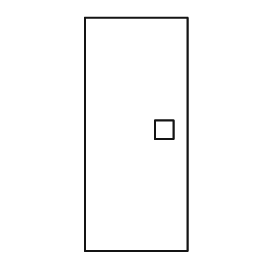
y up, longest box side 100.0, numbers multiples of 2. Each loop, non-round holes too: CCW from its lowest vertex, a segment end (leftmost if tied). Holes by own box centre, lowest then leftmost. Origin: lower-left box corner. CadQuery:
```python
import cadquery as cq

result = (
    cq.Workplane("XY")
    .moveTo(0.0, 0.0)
    .lineTo(44.0, 0.0)
    .lineTo(44.0, 100.0)
    .lineTo(0.0, 100.0)
    .close()
    .moveTo(30.0, 48.0)
    .lineTo(38.0, 48.0)
    .lineTo(38.0, 56.0)
    .lineTo(30.0, 56.0)
    .close()
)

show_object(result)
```